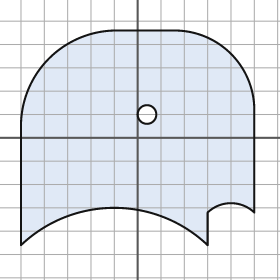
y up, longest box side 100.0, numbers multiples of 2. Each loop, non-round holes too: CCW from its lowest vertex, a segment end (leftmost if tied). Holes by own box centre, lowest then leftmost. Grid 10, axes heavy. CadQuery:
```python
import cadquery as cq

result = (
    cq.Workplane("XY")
    .moveTo(-50.0, -46.0)
    .threePointArc((-10.0, -30.0), (30.0, -46.0))
    .lineTo(30.0, -32.0)
    .threePointArc((40.0, -28.0), (50.0, -32.0))
    .lineTo(50.0, 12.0)
    .threePointArc((40.0, 36.0), (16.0, 46.0))
    .lineTo(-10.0, 46.0)
    .threePointArc((-38.0, 34.0), (-50.0, 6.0))
    .close()
    .moveTo(4.0, 10.0)
    .circle(4.0)
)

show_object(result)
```